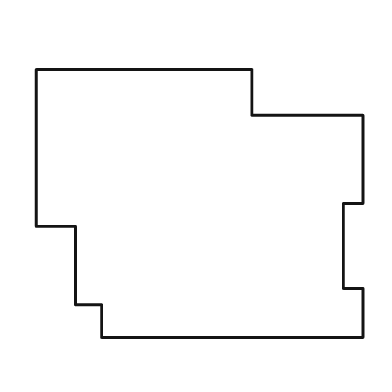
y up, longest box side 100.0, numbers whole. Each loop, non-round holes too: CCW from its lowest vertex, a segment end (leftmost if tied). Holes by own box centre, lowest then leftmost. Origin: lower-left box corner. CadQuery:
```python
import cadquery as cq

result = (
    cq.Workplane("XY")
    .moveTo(20.0, 0.0)
    .lineTo(100.0, 0.0)
    .lineTo(100.0, 15.0)
    .lineTo(94.0, 15.0)
    .lineTo(94.0, 41.0)
    .lineTo(100.0, 41.0)
    .lineTo(100.0, 68.0)
    .lineTo(66.0, 68.0)
    .lineTo(66.0, 82.0)
    .lineTo(0.0, 82.0)
    .lineTo(0.0, 34.0)
    .lineTo(12.0, 34.0)
    .lineTo(12.0, 10.0)
    .lineTo(20.0, 10.0)
    .close()
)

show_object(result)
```